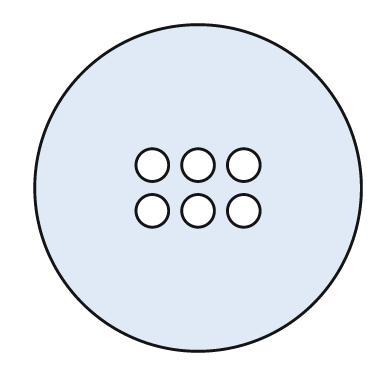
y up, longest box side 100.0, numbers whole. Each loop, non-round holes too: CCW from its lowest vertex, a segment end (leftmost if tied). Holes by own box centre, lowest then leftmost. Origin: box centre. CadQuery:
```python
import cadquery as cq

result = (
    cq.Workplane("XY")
    .moveTo(0.0, 0.0)
    .circle(50.0)
    .moveTo(-14.0, -7.0)
    .circle(5.0)
    .moveTo(0.0, -7.0)
    .circle(5.0)
    .moveTo(14.0, -7.0)
    .circle(5.0)
    .moveTo(-14.0, 7.0)
    .circle(5.0)
    .moveTo(0.0, 7.0)
    .circle(5.0)
    .moveTo(14.0, 7.0)
    .circle(5.0)
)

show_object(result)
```